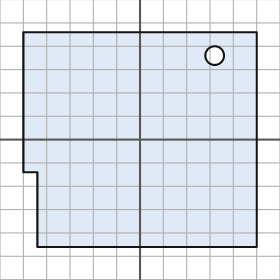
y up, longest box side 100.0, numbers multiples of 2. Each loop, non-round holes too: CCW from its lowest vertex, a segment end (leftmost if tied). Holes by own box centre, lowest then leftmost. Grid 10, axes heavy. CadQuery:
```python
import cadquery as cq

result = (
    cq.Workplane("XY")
    .moveTo(-44.0, -46.0)
    .lineTo(50.0, -46.0)
    .lineTo(50.0, 46.0)
    .lineTo(-50.0, 46.0)
    .lineTo(-50.0, -14.0)
    .lineTo(-44.0, -14.0)
    .close()
    .moveTo(32.0, 36.0)
    .circle(4.0)
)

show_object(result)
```